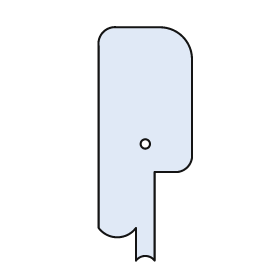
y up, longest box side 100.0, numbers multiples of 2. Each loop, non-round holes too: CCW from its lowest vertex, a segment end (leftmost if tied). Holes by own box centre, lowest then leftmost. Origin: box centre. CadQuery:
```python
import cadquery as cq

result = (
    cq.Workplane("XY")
    .moveTo(-4.0, -50.0)
    .threePointArc((0.0, -48.0), (4.0, -50.0))
    .lineTo(4.0, -12.0)
    .lineTo(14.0, -12.0)
    .threePointArc((18.0, -10.0), (20.0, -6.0))
    .lineTo(20.0, 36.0)
    .threePointArc((16.0, 46.0), (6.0, 50.0))
    .lineTo(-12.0, 50.0)
    .threePointArc((-18.0, 48.0), (-20.0, 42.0))
    .lineTo(-20.0, -36.0)
    .threePointArc((-12.0, -40.0), (-4.0, -36.0))
    .close()
    .moveTo(0.0, 0.0)
    .circle(2.0)
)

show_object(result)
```